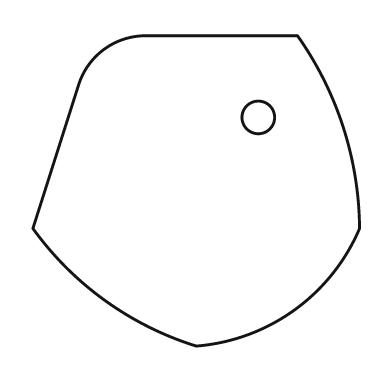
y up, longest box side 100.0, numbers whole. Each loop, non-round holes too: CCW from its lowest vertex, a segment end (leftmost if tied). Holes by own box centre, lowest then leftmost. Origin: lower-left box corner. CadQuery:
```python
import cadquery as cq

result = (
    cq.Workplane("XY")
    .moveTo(50.0, 0.0)
    .threePointArc((80.0, 11.0), (100.0, 36.0))
    .threePointArc((95.0, 67.0), (81.0, 95.0))
    .lineTo(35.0, 95.0)
    .threePointArc((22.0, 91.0), (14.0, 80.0))
    .lineTo(0.0, 36.0)
    .threePointArc((22.0, 14.0), (50.0, 0.0))
    .close()
    .moveTo(69.0, 70.0)
    .circle(5.0)
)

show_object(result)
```